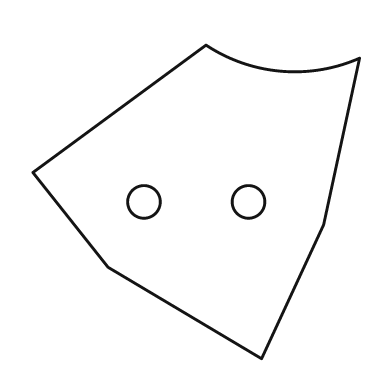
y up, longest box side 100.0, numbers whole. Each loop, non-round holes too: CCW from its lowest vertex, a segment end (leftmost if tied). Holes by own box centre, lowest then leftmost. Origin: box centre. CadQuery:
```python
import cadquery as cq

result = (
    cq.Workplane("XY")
    .moveTo(20.0, -48.0)
    .lineTo(39.0, -7.0)
    .lineTo(50.0, 44.0)
    .threePointArc((26.0, 40.0), (3.0, 48.0))
    .lineTo(-50.0, 9.0)
    .lineTo(-27.0, -20.0)
    .close()
    .moveTo(-16.0, 0.0)
    .circle(5.0)
    .moveTo(16.0, 0.0)
    .circle(5.0)
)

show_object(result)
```